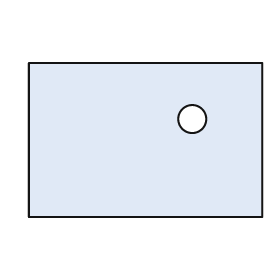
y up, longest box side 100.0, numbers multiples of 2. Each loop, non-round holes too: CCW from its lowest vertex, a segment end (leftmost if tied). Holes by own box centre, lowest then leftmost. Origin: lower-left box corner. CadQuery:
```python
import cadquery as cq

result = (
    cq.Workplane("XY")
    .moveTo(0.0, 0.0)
    .lineTo(100.0, 0.0)
    .lineTo(100.0, 66.0)
    .lineTo(0.0, 66.0)
    .close()
    .moveTo(70.0, 42.0)
    .circle(6.0)
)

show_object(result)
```